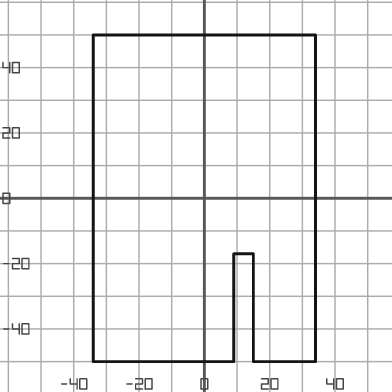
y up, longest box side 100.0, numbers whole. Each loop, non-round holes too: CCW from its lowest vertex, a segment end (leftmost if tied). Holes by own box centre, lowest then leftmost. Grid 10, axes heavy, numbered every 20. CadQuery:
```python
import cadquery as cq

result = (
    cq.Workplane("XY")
    .moveTo(-34.0, -50.0)
    .lineTo(9.0, -50.0)
    .lineTo(9.0, -17.0)
    .lineTo(15.0, -17.0)
    .lineTo(15.0, -50.0)
    .lineTo(34.0, -50.0)
    .lineTo(34.0, 50.0)
    .lineTo(-34.0, 50.0)
    .close()
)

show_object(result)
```